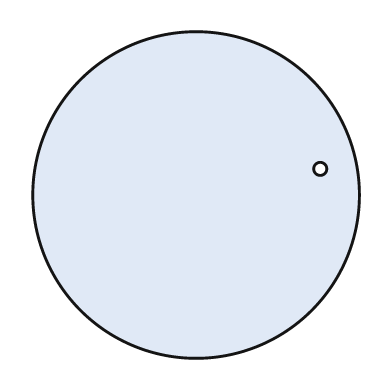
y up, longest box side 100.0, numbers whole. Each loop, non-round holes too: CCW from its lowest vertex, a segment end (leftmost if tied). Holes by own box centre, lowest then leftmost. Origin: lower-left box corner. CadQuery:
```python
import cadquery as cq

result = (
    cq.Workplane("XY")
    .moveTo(50.0, 50.0)
    .circle(50.0)
    .moveTo(88.0, 58.0)
    .circle(2.0)
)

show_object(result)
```